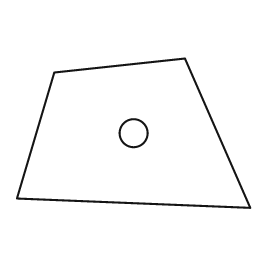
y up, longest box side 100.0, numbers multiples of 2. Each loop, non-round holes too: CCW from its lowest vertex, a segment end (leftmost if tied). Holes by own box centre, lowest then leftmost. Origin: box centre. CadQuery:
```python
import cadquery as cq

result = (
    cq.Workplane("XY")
    .moveTo(50.0, -32.0)
    .lineTo(22.0, 32.0)
    .lineTo(-34.0, 26.0)
    .lineTo(-50.0, -28.0)
    .close()
    .moveTo(0.0, 0.0)
    .circle(6.0)
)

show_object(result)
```